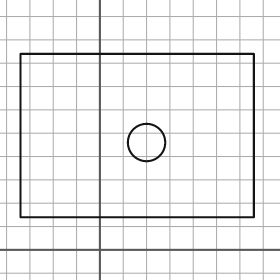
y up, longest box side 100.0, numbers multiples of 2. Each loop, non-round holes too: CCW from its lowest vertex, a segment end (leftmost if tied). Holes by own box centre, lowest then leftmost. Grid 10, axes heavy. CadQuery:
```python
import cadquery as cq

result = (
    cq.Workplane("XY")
    .moveTo(-34.0, 14.0)
    .lineTo(66.0, 14.0)
    .lineTo(66.0, 84.0)
    .lineTo(-34.0, 84.0)
    .close()
    .moveTo(20.0, 46.0)
    .circle(8.0)
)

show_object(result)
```